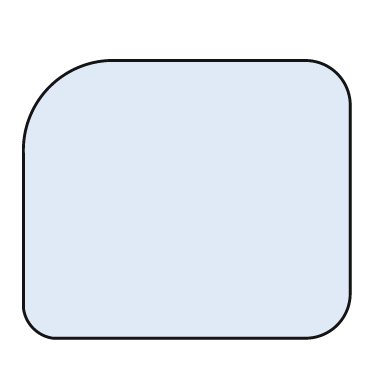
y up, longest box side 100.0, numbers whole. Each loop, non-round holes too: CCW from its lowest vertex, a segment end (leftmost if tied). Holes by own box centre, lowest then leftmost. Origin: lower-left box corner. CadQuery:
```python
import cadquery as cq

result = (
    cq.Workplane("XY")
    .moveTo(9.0, 0.0)
    .lineTo(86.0, 0.0)
    .threePointArc((96.0, 4.0), (100.0, 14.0))
    .lineTo(100.0, 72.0)
    .threePointArc((96.0, 81.0), (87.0, 85.0))
    .lineTo(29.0, 85.0)
    .threePointArc((8.0, 77.0), (0.0, 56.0))
    .lineTo(0.0, 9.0)
    .threePointArc((3.0, 3.0), (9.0, 0.0))
    .close()
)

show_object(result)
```